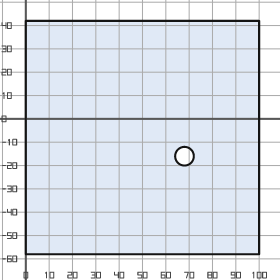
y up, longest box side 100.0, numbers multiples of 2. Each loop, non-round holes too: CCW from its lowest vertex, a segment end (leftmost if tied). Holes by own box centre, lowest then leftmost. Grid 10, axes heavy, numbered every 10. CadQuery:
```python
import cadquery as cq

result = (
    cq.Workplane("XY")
    .moveTo(0.0, -58.0)
    .lineTo(100.0, -58.0)
    .lineTo(100.0, 42.0)
    .lineTo(0.0, 42.0)
    .close()
    .moveTo(68.0, -16.0)
    .circle(4.0)
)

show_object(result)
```